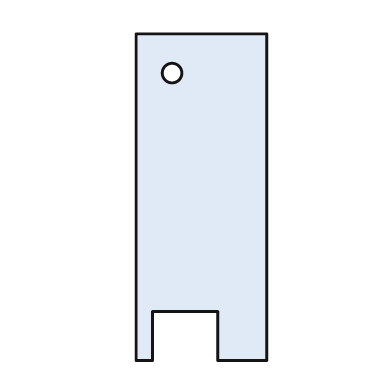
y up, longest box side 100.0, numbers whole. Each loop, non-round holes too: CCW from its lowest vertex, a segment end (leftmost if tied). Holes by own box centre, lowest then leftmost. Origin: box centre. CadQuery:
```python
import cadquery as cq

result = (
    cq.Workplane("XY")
    .moveTo(-20.0, -50.0)
    .lineTo(-15.0, -50.0)
    .lineTo(-15.0, -35.0)
    .lineTo(5.0, -35.0)
    .lineTo(5.0, -50.0)
    .lineTo(20.0, -50.0)
    .lineTo(20.0, 50.0)
    .lineTo(-20.0, 50.0)
    .close()
    .moveTo(-9.0, 38.0)
    .circle(3.0)
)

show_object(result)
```